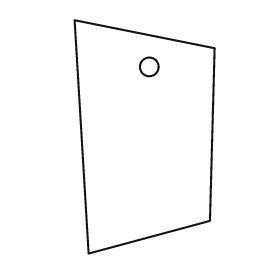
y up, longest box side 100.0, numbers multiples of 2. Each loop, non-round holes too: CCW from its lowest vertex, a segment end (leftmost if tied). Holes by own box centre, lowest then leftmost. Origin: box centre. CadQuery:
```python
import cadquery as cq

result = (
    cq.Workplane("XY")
    .moveTo(-24.0, -50.0)
    .lineTo(28.0, -36.0)
    .lineTo(30.0, 38.0)
    .lineTo(-30.0, 50.0)
    .close()
    .moveTo(2.0, 30.0)
    .circle(4.0)
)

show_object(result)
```